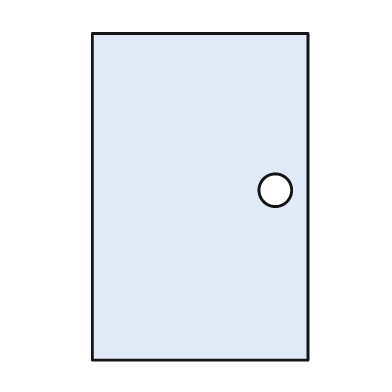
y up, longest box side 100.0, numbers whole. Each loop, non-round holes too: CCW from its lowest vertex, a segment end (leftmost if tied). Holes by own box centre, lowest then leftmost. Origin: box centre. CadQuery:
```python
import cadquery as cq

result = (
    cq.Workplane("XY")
    .moveTo(-33.0, -50.0)
    .lineTo(33.0, -50.0)
    .lineTo(33.0, 50.0)
    .lineTo(-33.0, 50.0)
    .close()
    .moveTo(23.0, 2.0)
    .circle(5.0)
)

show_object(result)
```